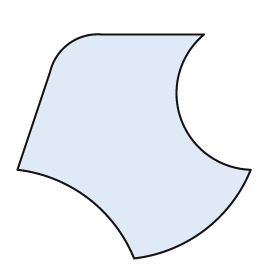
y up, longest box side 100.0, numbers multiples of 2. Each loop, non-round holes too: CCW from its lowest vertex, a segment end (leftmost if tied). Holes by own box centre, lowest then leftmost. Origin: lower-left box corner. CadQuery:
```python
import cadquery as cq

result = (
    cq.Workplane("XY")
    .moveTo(50.0, 0.0)
    .threePointArc((80.0, 12.0), (100.0, 38.0))
    .threePointArc((70.0, 60.0), (80.0, 96.0))
    .lineTo(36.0, 96.0)
    .threePointArc((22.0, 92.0), (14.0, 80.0))
    .lineTo(0.0, 38.0)
    .threePointArc((30.0, 26.0), (50.0, 0.0))
    .close()
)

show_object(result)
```